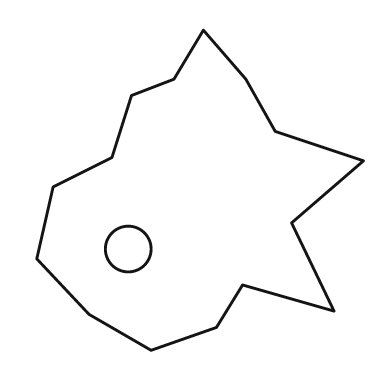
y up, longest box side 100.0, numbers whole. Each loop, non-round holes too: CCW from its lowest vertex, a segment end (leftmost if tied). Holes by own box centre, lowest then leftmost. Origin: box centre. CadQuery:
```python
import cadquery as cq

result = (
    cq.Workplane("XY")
    .moveTo(-15.0, -49.0)
    .lineTo(5.0, -42.0)
    .lineTo(13.0, -29.0)
    .lineTo(41.0, -37.0)
    .lineTo(28.0, -10.0)
    .lineTo(50.0, 9.0)
    .lineTo(23.0, 18.0)
    .lineTo(14.0, 34.0)
    .lineTo(1.0, 49.0)
    .lineTo(-8.0, 34.0)
    .lineTo(-21.0, 29.0)
    .lineTo(-27.0, 10.0)
    .lineTo(-45.0, 1.0)
    .lineTo(-50.0, -21.0)
    .lineTo(-34.0, -38.0)
    .close()
    .moveTo(-22.0, -18.0)
    .circle(7.0)
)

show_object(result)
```